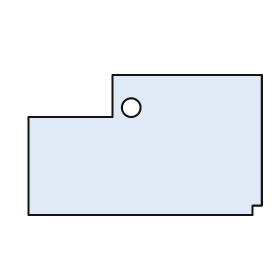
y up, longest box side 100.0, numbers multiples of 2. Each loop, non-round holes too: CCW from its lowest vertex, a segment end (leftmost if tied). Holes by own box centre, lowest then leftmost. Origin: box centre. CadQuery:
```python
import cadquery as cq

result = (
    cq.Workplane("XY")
    .moveTo(-50.0, -30.0)
    .lineTo(46.0, -30.0)
    .lineTo(46.0, -26.0)
    .lineTo(50.0, -26.0)
    .lineTo(50.0, 30.0)
    .lineTo(-14.0, 30.0)
    .lineTo(-14.0, 12.0)
    .lineTo(-50.0, 12.0)
    .close()
    .moveTo(-6.0, 16.0)
    .circle(4.0)
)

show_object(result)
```